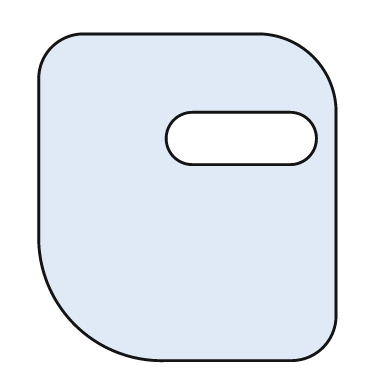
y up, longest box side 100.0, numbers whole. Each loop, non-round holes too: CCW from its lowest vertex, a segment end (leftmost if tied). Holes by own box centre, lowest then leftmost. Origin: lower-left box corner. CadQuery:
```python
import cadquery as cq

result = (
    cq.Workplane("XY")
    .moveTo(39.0, 0.0)
    .lineTo(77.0, 0.0)
    .threePointArc((87.0, 4.0), (91.0, 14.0))
    .lineTo(91.0, 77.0)
    .threePointArc((84.0, 93.0), (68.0, 100.0))
    .lineTo(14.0, 100.0)
    .threePointArc((4.0, 96.0), (0.0, 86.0))
    .lineTo(0.0, 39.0)
    .threePointArc((11.0, 11.0), (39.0, 0.0))
    .close()
    .moveTo(47.0, 60.0)
    .lineTo(77.0, 60.0)
    .threePointArc((85.0, 68.0), (77.0, 76.0))
    .lineTo(47.0, 76.0)
    .threePointArc((39.0, 68.0), (47.0, 60.0))
    .close()
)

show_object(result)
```